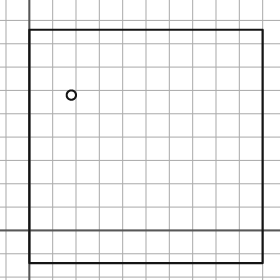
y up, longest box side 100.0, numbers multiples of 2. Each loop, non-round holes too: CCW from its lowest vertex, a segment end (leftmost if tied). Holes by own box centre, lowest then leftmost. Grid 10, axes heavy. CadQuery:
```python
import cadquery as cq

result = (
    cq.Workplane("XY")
    .moveTo(0.0, -14.0)
    .lineTo(100.0, -14.0)
    .lineTo(100.0, 86.0)
    .lineTo(0.0, 86.0)
    .close()
    .moveTo(18.0, 58.0)
    .circle(2.0)
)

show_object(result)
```